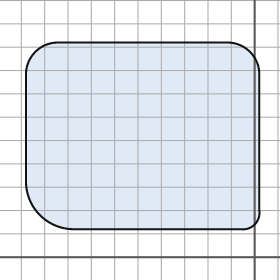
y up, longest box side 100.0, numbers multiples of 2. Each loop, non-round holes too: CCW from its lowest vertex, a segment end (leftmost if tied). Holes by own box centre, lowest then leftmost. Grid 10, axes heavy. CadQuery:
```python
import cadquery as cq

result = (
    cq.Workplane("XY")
    .moveTo(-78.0, 12.0)
    .lineTo(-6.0, 12.0)
    .threePointArc((0.0, 14.0), (2.0, 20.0))
    .lineTo(2.0, 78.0)
    .threePointArc((-2.0, 88.0), (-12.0, 92.0))
    .lineTo(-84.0, 92.0)
    .threePointArc((-94.0, 88.0), (-98.0, 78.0))
    .lineTo(-98.0, 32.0)
    .threePointArc((-92.0, 18.0), (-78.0, 12.0))
    .close()
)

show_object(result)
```